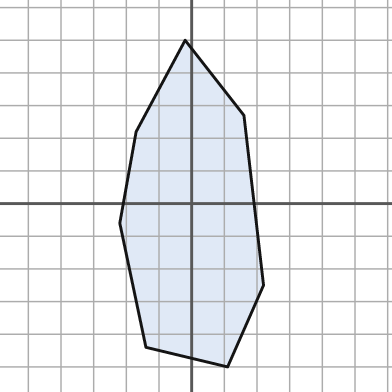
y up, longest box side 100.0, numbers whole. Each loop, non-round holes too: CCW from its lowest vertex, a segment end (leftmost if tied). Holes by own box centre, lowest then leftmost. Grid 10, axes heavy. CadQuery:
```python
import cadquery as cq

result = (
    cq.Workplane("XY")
    .moveTo(11.0, -50.0)
    .lineTo(22.0, -25.0)
    .lineTo(16.0, 27.0)
    .lineTo(-2.0, 50.0)
    .lineTo(-17.0, 22.0)
    .lineTo(-22.0, -6.0)
    .lineTo(-14.0, -44.0)
    .close()
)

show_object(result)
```